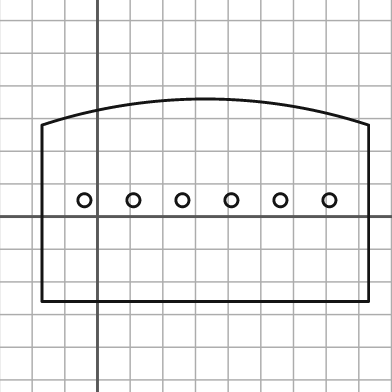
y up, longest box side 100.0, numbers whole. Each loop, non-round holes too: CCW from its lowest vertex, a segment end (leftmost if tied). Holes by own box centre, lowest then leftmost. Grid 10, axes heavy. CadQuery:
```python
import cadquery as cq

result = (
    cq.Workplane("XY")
    .moveTo(-17.0, -26.0)
    .lineTo(83.0, -26.0)
    .lineTo(83.0, 28.0)
    .threePointArc((33.0, 36.0), (-17.0, 28.0))
    .close()
    .moveTo(-4.0, 5.0)
    .circle(2.0)
    .moveTo(11.0, 5.0)
    .circle(2.0)
    .moveTo(26.0, 5.0)
    .circle(2.0)
    .moveTo(41.0, 5.0)
    .circle(2.0)
    .moveTo(56.0, 5.0)
    .circle(2.0)
    .moveTo(71.0, 5.0)
    .circle(2.0)
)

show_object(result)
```